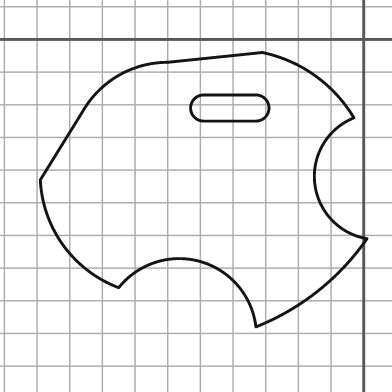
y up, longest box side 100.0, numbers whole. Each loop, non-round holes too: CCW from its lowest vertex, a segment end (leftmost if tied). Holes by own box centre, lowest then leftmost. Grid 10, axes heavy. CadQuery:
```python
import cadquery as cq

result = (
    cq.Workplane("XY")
    .moveTo(-33.0, -88.0)
    .threePointArc((-14.0, -77.0), (1.0, -61.0))
    .threePointArc((-15.0, -44.0), (-3.0, -24.0))
    .threePointArc((-15.0, -11.0), (-31.0, -4.0))
    .lineTo(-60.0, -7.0)
    .threePointArc((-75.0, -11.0), (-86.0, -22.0))
    .lineTo(-99.0, -43.0)
    .threePointArc((-92.0, -63.0), (-75.0, -76.0))
    .threePointArc((-50.0, -68.0), (-33.0, -88.0))
    .close()
    .moveTo(-49.0, -25.0)
    .lineTo(-33.0, -25.0)
    .threePointArc((-29.0, -21.0), (-33.0, -17.0))
    .lineTo(-49.0, -17.0)
    .threePointArc((-53.0, -21.0), (-49.0, -25.0))
    .close()
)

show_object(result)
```